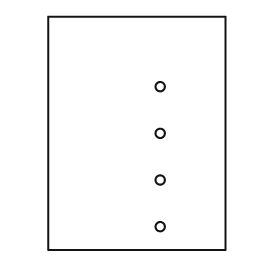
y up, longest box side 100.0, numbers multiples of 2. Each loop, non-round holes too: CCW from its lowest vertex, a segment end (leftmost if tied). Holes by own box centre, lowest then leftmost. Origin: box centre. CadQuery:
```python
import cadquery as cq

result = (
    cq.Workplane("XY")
    .moveTo(-38.0, -50.0)
    .lineTo(38.0, -50.0)
    .lineTo(38.0, 50.0)
    .lineTo(-38.0, 50.0)
    .close()
    .moveTo(10.0, -40.0)
    .circle(2.0)
    .moveTo(10.0, -20.0)
    .circle(2.0)
    .moveTo(10.0, 0.0)
    .circle(2.0)
    .moveTo(10.0, 20.0)
    .circle(2.0)
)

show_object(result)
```